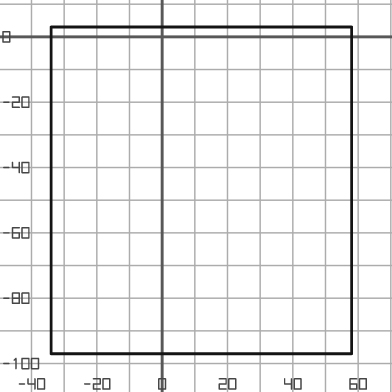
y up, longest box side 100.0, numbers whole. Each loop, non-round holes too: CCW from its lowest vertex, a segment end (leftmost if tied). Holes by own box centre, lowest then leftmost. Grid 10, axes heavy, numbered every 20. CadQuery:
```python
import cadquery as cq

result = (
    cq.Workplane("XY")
    .moveTo(-34.0, -97.0)
    .lineTo(58.0, -97.0)
    .lineTo(58.0, 3.0)
    .lineTo(-34.0, 3.0)
    .close()
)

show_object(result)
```